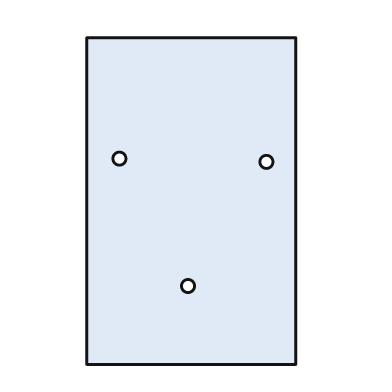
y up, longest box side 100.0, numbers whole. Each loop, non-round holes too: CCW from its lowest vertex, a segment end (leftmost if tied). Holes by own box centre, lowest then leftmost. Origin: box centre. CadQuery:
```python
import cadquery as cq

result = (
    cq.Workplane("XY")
    .moveTo(-32.0, -50.0)
    .lineTo(32.0, -50.0)
    .lineTo(32.0, 50.0)
    .lineTo(-32.0, 50.0)
    .close()
    .moveTo(-1.0, -26.0)
    .circle(2.0)
    .moveTo(23.0, 12.0)
    .circle(2.0)
    .moveTo(-22.0, 13.0)
    .circle(2.0)
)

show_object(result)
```